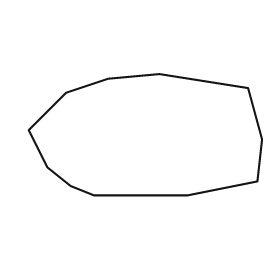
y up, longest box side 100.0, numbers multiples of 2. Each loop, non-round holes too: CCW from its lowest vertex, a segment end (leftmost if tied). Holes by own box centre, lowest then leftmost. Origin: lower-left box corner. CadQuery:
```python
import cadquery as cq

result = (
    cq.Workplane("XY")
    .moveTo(28.0, 0.0)
    .lineTo(68.0, 0.0)
    .lineTo(98.0, 6.0)
    .lineTo(100.0, 24.0)
    .lineTo(94.0, 46.0)
    .lineTo(56.0, 52.0)
    .lineTo(34.0, 50.0)
    .lineTo(16.0, 44.0)
    .lineTo(0.0, 28.0)
    .lineTo(8.0, 12.0)
    .lineTo(18.0, 4.0)
    .close()
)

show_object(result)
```